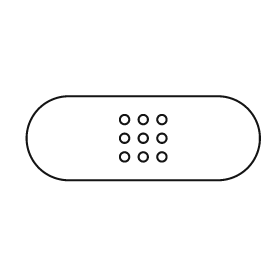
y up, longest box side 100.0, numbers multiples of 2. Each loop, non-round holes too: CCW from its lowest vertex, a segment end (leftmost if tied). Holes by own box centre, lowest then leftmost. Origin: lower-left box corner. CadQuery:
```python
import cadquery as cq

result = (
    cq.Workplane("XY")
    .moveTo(18.0, 0.0)
    .lineTo(82.0, 0.0)
    .threePointArc((100.0, 18.0), (82.0, 36.0))
    .lineTo(18.0, 36.0)
    .threePointArc((0.0, 18.0), (18.0, 0.0))
    .close()
    .moveTo(42.0, 10.0)
    .circle(2.0)
    .moveTo(50.0, 10.0)
    .circle(2.0)
    .moveTo(58.0, 10.0)
    .circle(2.0)
    .moveTo(42.0, 18.0)
    .circle(2.0)
    .moveTo(50.0, 18.0)
    .circle(2.0)
    .moveTo(58.0, 18.0)
    .circle(2.0)
    .moveTo(42.0, 26.0)
    .circle(2.0)
    .moveTo(50.0, 26.0)
    .circle(2.0)
    .moveTo(58.0, 26.0)
    .circle(2.0)
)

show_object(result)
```